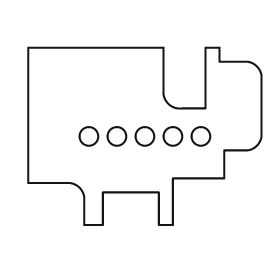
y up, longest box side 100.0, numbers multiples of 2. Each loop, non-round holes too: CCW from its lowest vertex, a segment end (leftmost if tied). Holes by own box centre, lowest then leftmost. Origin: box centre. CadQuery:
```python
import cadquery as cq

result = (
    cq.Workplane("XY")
    .moveTo(-26.0, -38.0)
    .lineTo(-18.0, -38.0)
    .lineTo(-18.0, -24.0)
    .lineTo(6.0, -24.0)
    .lineTo(6.0, -38.0)
    .lineTo(12.0, -38.0)
    .lineTo(12.0, -18.0)
    .lineTo(34.0, -18.0)
    .lineTo(34.0, -6.0)
    .lineTo(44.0, -6.0)
    .threePointArc((48.0, -4.0), (50.0, 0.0))
    .lineTo(50.0, 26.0)
    .threePointArc((48.0, 30.0), (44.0, 32.0))
    .lineTo(32.0, 32.0)
    .lineTo(32.0, 38.0)
    .lineTo(26.0, 38.0)
    .lineTo(26.0, 12.0)
    .lineTo(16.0, 12.0)
    .threePointArc((10.0, 14.0), (8.0, 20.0))
    .lineTo(8.0, 38.0)
    .lineTo(-50.0, 38.0)
    .lineTo(-50.0, -20.0)
    .lineTo(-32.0, -20.0)
    .threePointArc((-28.0, -22.0), (-26.0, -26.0))
    .close()
    .moveTo(-24.0, 0.0)
    .circle(4.0)
    .moveTo(-12.0, 0.0)
    .circle(4.0)
    .moveTo(0.0, 0.0)
    .circle(4.0)
    .moveTo(12.0, 0.0)
    .circle(4.0)
    .moveTo(24.0, 0.0)
    .circle(4.0)
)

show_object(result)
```